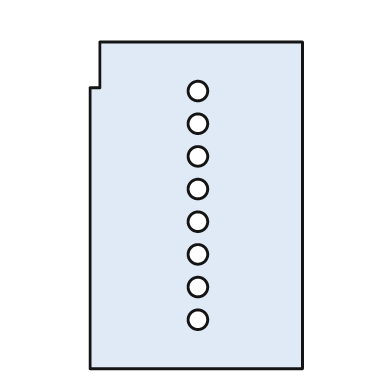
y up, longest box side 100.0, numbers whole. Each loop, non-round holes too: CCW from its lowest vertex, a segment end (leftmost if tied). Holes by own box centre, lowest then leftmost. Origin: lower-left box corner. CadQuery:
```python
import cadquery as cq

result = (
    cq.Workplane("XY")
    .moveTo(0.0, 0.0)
    .lineTo(65.0, 0.0)
    .lineTo(65.0, 100.0)
    .lineTo(3.0, 100.0)
    .lineTo(3.0, 86.0)
    .lineTo(0.0, 86.0)
    .close()
    .moveTo(33.0, 15.0)
    .circle(3.0)
    .moveTo(33.0, 25.0)
    .circle(3.0)
    .moveTo(33.0, 35.0)
    .circle(3.0)
    .moveTo(33.0, 45.0)
    .circle(3.0)
    .moveTo(33.0, 55.0)
    .circle(3.0)
    .moveTo(33.0, 65.0)
    .circle(3.0)
    .moveTo(33.0, 75.0)
    .circle(3.0)
    .moveTo(33.0, 85.0)
    .circle(3.0)
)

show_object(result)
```